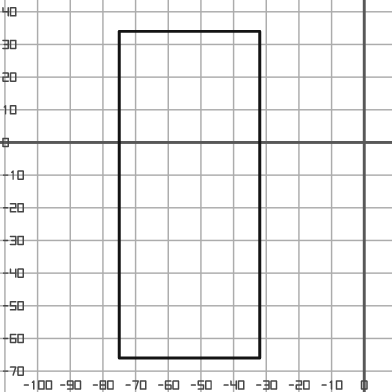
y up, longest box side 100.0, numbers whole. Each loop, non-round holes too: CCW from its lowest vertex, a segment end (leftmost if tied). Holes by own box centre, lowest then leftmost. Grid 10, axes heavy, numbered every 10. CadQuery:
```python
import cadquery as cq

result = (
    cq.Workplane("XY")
    .moveTo(-75.0, -66.0)
    .lineTo(-32.0, -66.0)
    .lineTo(-32.0, 34.0)
    .lineTo(-75.0, 34.0)
    .close()
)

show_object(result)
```